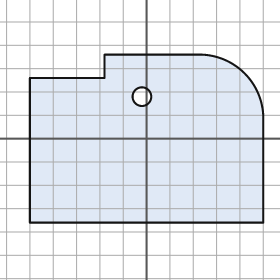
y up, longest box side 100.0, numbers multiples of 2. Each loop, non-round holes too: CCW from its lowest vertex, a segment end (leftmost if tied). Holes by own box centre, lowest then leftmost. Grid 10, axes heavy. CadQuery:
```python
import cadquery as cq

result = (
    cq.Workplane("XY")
    .moveTo(-50.0, -36.0)
    .lineTo(50.0, -36.0)
    .lineTo(50.0, 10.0)
    .threePointArc((42.0, 28.0), (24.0, 36.0))
    .lineTo(-18.0, 36.0)
    .lineTo(-18.0, 26.0)
    .lineTo(-50.0, 26.0)
    .close()
    .moveTo(-2.0, 18.0)
    .circle(4.0)
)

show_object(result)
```